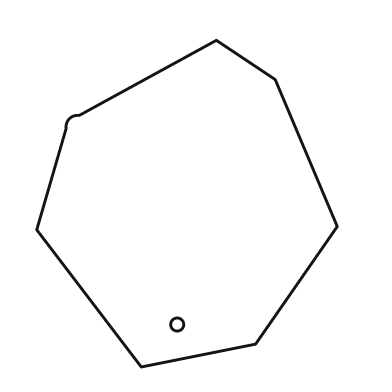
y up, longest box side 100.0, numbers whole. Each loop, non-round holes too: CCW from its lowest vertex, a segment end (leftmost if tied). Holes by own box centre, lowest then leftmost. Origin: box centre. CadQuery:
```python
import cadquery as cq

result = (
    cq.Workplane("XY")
    .moveTo(-14.0, -50.0)
    .lineTo(21.0, -43.0)
    .lineTo(46.0, -7.0)
    .lineTo(27.0, 38.0)
    .lineTo(9.0, 50.0)
    .lineTo(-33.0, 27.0)
    .threePointArc((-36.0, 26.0), (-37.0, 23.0))
    .lineTo(-46.0, -8.0)
    .close()
    .moveTo(-3.0, -37.0)
    .circle(2.0)
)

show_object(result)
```